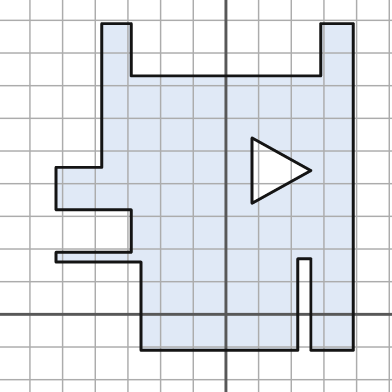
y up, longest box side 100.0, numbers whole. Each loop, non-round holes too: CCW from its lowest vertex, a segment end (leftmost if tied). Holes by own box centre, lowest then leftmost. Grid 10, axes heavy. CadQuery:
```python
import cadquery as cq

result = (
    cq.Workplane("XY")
    .moveTo(-26.0, -11.0)
    .lineTo(22.0, -11.0)
    .lineTo(22.0, 17.0)
    .lineTo(26.0, 17.0)
    .lineTo(26.0, -11.0)
    .lineTo(39.0, -11.0)
    .lineTo(39.0, 89.0)
    .lineTo(29.0, 89.0)
    .lineTo(29.0, 73.0)
    .lineTo(-29.0, 73.0)
    .lineTo(-29.0, 89.0)
    .lineTo(-38.0, 89.0)
    .lineTo(-38.0, 45.0)
    .lineTo(-52.0, 45.0)
    .lineTo(-52.0, 32.0)
    .lineTo(-29.0, 32.0)
    .lineTo(-29.0, 19.0)
    .lineTo(-52.0, 19.0)
    .lineTo(-52.0, 16.0)
    .lineTo(-26.0, 16.0)
    .close()
    .moveTo(8.0, 34.0)
    .lineTo(26.0, 44.0)
    .lineTo(8.0, 54.0)
    .close()
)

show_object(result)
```